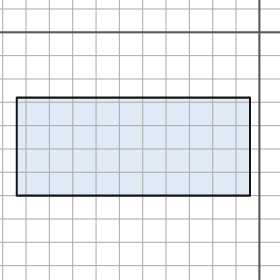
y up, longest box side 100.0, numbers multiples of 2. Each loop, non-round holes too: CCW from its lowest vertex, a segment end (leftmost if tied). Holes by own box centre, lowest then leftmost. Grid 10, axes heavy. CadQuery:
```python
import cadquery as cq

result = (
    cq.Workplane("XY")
    .moveTo(-104.0, -70.0)
    .lineTo(-4.0, -70.0)
    .lineTo(-4.0, -28.0)
    .lineTo(-104.0, -28.0)
    .close()
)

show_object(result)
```